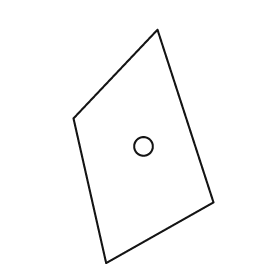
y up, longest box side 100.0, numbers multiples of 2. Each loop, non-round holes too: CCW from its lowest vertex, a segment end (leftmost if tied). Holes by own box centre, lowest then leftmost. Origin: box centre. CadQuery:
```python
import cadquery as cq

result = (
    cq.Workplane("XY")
    .moveTo(-16.0, -50.0)
    .lineTo(30.0, -24.0)
    .lineTo(6.0, 50.0)
    .lineTo(-30.0, 12.0)
    .close()
    .moveTo(0.0, 0.0)
    .circle(4.0)
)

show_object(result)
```